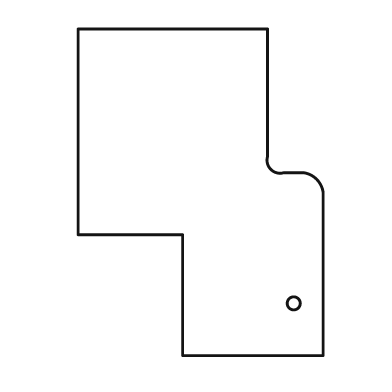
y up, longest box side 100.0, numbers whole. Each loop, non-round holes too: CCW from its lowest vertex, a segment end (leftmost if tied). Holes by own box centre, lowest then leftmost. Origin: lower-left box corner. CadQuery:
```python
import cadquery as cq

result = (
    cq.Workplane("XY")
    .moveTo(32.0, 0.0)
    .lineTo(75.0, 0.0)
    .lineTo(75.0, 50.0)
    .threePointArc((73.0, 54.0), (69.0, 56.0))
    .lineTo(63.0, 56.0)
    .threePointArc((59.0, 57.0), (58.0, 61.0))
    .lineTo(58.0, 100.0)
    .lineTo(0.0, 100.0)
    .lineTo(0.0, 37.0)
    .lineTo(32.0, 37.0)
    .close()
    .moveTo(66.0, 16.0)
    .circle(2.0)
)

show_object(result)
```